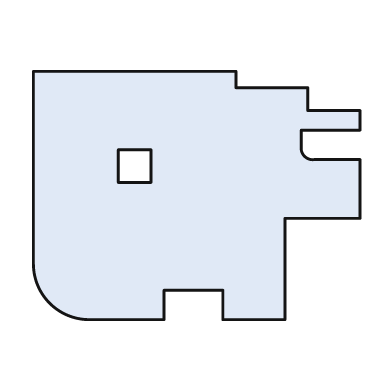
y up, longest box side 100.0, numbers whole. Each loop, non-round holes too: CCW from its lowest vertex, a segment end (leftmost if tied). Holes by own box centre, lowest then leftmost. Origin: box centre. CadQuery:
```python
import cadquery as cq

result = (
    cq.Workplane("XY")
    .moveTo(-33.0, -38.0)
    .lineTo(-10.0, -38.0)
    .lineTo(-10.0, -29.0)
    .lineTo(8.0, -29.0)
    .lineTo(8.0, -38.0)
    .lineTo(27.0, -38.0)
    .lineTo(27.0, -7.0)
    .lineTo(50.0, -7.0)
    .lineTo(50.0, 11.0)
    .lineTo(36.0, 11.0)
    .threePointArc((33.0, 12.0), (32.0, 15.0))
    .lineTo(32.0, 20.0)
    .lineTo(50.0, 20.0)
    .lineTo(50.0, 26.0)
    .lineTo(34.0, 26.0)
    .lineTo(34.0, 33.0)
    .lineTo(12.0, 33.0)
    .lineTo(12.0, 38.0)
    .lineTo(-50.0, 38.0)
    .lineTo(-50.0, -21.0)
    .threePointArc((-45.0, -33.0), (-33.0, -38.0))
    .close()
    .moveTo(-24.0, 4.0)
    .lineTo(-14.0, 4.0)
    .lineTo(-14.0, 14.0)
    .lineTo(-24.0, 14.0)
    .close()
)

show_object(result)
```